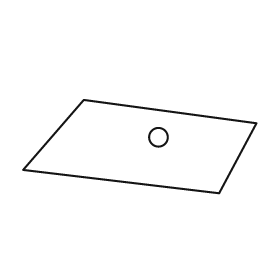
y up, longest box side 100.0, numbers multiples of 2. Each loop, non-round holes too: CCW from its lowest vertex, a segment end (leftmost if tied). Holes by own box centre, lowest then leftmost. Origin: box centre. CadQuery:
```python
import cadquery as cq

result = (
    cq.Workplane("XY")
    .moveTo(34.0, -20.0)
    .lineTo(50.0, 10.0)
    .lineTo(-24.0, 20.0)
    .lineTo(-50.0, -10.0)
    .close()
    .moveTo(8.0, 4.0)
    .circle(4.0)
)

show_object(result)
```